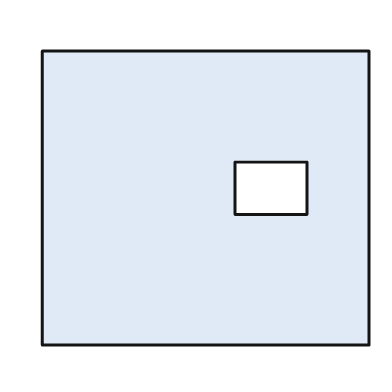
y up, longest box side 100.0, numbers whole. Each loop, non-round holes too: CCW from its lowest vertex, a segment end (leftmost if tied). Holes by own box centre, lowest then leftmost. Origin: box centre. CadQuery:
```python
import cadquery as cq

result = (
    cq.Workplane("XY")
    .moveTo(-50.0, -45.0)
    .lineTo(50.0, -45.0)
    .lineTo(50.0, 45.0)
    .lineTo(-50.0, 45.0)
    .close()
    .moveTo(9.0, -5.0)
    .lineTo(31.0, -5.0)
    .lineTo(31.0, 11.0)
    .lineTo(9.0, 11.0)
    .close()
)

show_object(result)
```